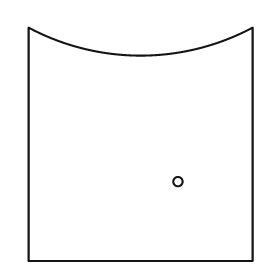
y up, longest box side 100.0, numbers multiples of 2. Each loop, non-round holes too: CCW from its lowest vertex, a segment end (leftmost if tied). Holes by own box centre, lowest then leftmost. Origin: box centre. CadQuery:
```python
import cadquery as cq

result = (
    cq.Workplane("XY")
    .moveTo(-48.0, -50.0)
    .lineTo(48.0, -50.0)
    .lineTo(48.0, 50.0)
    .threePointArc((0.0, 38.0), (-48.0, 50.0))
    .close()
    .moveTo(16.0, -16.0)
    .circle(2.0)
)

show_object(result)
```